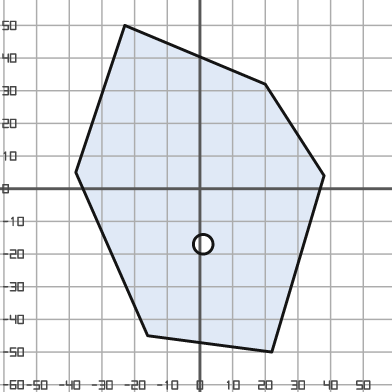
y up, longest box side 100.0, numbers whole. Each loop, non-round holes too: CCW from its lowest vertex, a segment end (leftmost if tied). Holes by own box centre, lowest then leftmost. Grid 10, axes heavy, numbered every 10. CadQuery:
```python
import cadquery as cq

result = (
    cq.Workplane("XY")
    .moveTo(22.0, -50.0)
    .lineTo(38.0, 4.0)
    .lineTo(20.0, 32.0)
    .lineTo(-23.0, 50.0)
    .lineTo(-38.0, 5.0)
    .lineTo(-16.0, -45.0)
    .close()
    .moveTo(1.0, -17.0)
    .circle(3.0)
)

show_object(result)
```